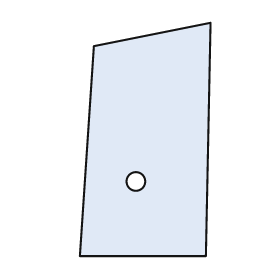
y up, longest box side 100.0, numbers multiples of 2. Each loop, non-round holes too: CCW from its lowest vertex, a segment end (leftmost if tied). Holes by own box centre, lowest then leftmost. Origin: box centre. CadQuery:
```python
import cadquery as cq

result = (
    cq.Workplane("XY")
    .moveTo(-28.0, -50.0)
    .lineTo(26.0, -50.0)
    .lineTo(28.0, 50.0)
    .lineTo(-22.0, 40.0)
    .close()
    .moveTo(-4.0, -18.0)
    .circle(4.0)
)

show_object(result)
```